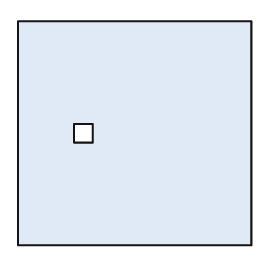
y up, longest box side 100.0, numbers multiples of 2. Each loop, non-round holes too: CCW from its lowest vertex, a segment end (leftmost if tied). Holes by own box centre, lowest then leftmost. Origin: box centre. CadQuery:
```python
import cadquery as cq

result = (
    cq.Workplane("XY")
    .moveTo(-50.0, -48.0)
    .lineTo(50.0, -48.0)
    .lineTo(50.0, 48.0)
    .lineTo(-50.0, 48.0)
    .close()
    .moveTo(-26.0, -4.0)
    .lineTo(-18.0, -4.0)
    .lineTo(-18.0, 4.0)
    .lineTo(-26.0, 4.0)
    .close()
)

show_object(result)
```